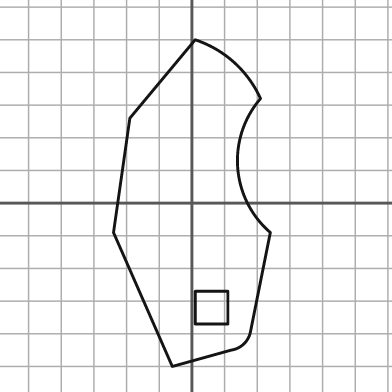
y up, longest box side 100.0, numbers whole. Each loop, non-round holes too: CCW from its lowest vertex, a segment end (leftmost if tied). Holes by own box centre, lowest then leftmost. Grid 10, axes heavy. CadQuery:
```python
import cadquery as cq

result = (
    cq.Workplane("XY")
    .moveTo(-6.0, -50.0)
    .lineTo(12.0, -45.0)
    .threePointArc((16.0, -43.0), (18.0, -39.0))
    .lineTo(24.0, -9.0)
    .threePointArc((14.0, 11.0), (21.0, 32.0))
    .threePointArc((13.0, 43.0), (1.0, 50.0))
    .lineTo(-19.0, 26.0)
    .lineTo(-24.0, -9.0)
    .close()
    .moveTo(1.0, -37.0)
    .lineTo(11.0, -37.0)
    .lineTo(11.0, -27.0)
    .lineTo(1.0, -27.0)
    .close()
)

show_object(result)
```